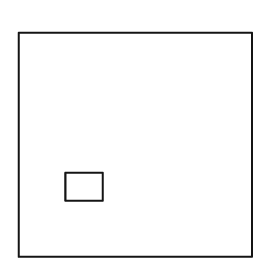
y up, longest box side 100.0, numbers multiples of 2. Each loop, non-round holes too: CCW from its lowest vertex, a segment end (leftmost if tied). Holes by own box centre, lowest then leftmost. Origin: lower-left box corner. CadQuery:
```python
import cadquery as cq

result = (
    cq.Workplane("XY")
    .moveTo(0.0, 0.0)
    .lineTo(100.0, 0.0)
    .lineTo(100.0, 96.0)
    .lineTo(0.0, 96.0)
    .close()
    .moveTo(20.0, 24.0)
    .lineTo(36.0, 24.0)
    .lineTo(36.0, 36.0)
    .lineTo(20.0, 36.0)
    .close()
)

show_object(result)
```